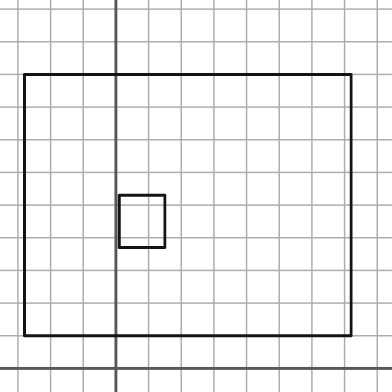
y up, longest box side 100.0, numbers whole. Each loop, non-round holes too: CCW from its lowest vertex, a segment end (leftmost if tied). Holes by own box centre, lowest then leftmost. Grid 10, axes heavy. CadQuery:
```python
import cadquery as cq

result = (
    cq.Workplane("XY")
    .moveTo(-28.0, 10.0)
    .lineTo(72.0, 10.0)
    .lineTo(72.0, 90.0)
    .lineTo(-28.0, 90.0)
    .close()
    .moveTo(1.0, 37.0)
    .lineTo(15.0, 37.0)
    .lineTo(15.0, 53.0)
    .lineTo(1.0, 53.0)
    .close()
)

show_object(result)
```